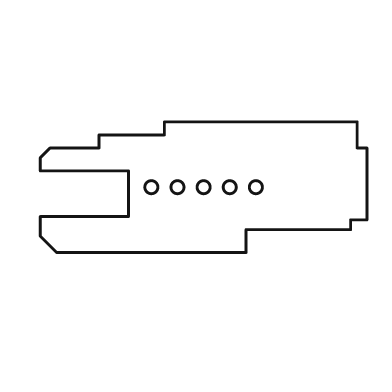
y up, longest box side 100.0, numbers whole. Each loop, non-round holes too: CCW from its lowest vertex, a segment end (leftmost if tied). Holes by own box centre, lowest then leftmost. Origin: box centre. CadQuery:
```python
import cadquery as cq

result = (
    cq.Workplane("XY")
    .moveTo(-45.0, -20.0)
    .lineTo(13.0, -20.0)
    .lineTo(13.0, -13.0)
    .lineTo(45.0, -13.0)
    .lineTo(45.0, -10.0)
    .lineTo(50.0, -10.0)
    .lineTo(50.0, 12.0)
    .lineTo(47.0, 12.0)
    .lineTo(47.0, 20.0)
    .lineTo(-12.0, 20.0)
    .lineTo(-12.0, 16.0)
    .lineTo(-32.0, 16.0)
    .lineTo(-32.0, 12.0)
    .lineTo(-47.0, 12.0)
    .lineTo(-50.0, 9.0)
    .lineTo(-50.0, 5.0)
    .lineTo(-23.0, 5.0)
    .lineTo(-23.0, -9.0)
    .lineTo(-50.0, -9.0)
    .lineTo(-50.0, -15.0)
    .close()
    .moveTo(-16.0, 0.0)
    .circle(2.0)
    .moveTo(-8.0, 0.0)
    .circle(2.0)
    .moveTo(0.0, 0.0)
    .circle(2.0)
    .moveTo(8.0, 0.0)
    .circle(2.0)
    .moveTo(16.0, 0.0)
    .circle(2.0)
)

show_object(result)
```